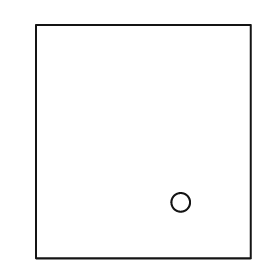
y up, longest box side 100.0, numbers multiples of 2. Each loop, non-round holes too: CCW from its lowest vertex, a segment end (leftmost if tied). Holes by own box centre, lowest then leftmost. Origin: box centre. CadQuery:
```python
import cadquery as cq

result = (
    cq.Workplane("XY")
    .moveTo(-46.0, -50.0)
    .lineTo(46.0, -50.0)
    .lineTo(46.0, 50.0)
    .lineTo(-46.0, 50.0)
    .close()
    .moveTo(16.0, -26.0)
    .circle(4.0)
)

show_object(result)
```